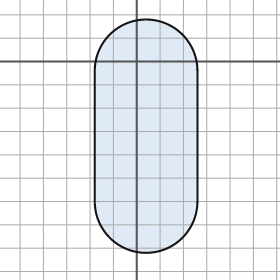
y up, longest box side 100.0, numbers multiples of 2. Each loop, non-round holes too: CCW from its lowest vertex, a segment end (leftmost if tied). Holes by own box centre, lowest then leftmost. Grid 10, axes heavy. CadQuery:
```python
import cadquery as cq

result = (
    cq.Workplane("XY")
    .moveTo(-18.0, -60.0)
    .threePointArc((4.0, -82.0), (26.0, -60.0))
    .lineTo(26.0, -4.0)
    .threePointArc((4.0, 18.0), (-18.0, -4.0))
    .close()
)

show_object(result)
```